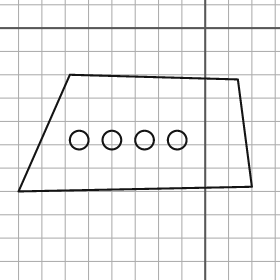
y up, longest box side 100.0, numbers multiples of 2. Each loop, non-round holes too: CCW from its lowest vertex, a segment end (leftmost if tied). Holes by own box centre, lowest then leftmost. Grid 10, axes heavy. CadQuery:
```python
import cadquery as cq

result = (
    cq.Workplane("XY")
    .moveTo(-80.0, -70.0)
    .lineTo(20.0, -68.0)
    .lineTo(14.0, -22.0)
    .lineTo(-58.0, -20.0)
    .close()
    .moveTo(-54.0, -48.0)
    .circle(4.0)
    .moveTo(-40.0, -48.0)
    .circle(4.0)
    .moveTo(-26.0, -48.0)
    .circle(4.0)
    .moveTo(-12.0, -48.0)
    .circle(4.0)
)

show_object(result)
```